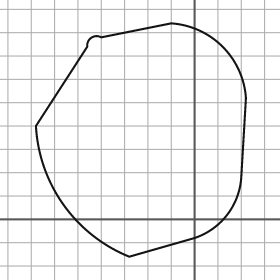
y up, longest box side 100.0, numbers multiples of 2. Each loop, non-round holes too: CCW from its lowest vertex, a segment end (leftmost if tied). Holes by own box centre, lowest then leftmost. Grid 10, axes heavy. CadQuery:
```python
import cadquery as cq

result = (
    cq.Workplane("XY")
    .moveTo(-28.0, -16.0)
    .lineTo(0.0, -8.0)
    .threePointArc((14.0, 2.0), (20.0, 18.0))
    .lineTo(22.0, 52.0)
    .threePointArc((12.0, 74.0), (-10.0, 84.0))
    .lineTo(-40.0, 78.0)
    .threePointArc((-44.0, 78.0), (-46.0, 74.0))
    .lineTo(-68.0, 40.0)
    .threePointArc((-56.0, 6.0), (-28.0, -16.0))
    .close()
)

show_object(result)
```